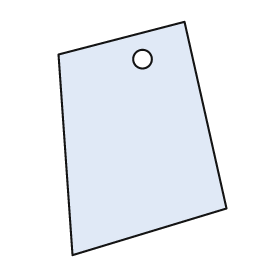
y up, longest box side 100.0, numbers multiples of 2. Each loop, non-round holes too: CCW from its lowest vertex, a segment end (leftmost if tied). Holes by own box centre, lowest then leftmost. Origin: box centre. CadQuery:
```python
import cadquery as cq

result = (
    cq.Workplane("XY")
    .moveTo(-30.0, -50.0)
    .lineTo(36.0, -30.0)
    .lineTo(18.0, 50.0)
    .lineTo(-36.0, 36.0)
    .close()
    .moveTo(0.0, 34.0)
    .circle(4.0)
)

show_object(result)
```